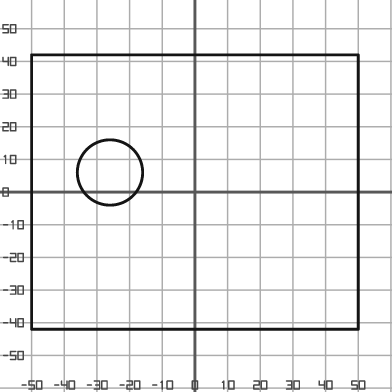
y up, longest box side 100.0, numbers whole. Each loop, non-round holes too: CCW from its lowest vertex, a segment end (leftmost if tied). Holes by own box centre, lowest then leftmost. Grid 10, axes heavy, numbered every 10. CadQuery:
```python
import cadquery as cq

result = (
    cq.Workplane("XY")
    .moveTo(-50.0, -42.0)
    .lineTo(50.0, -42.0)
    .lineTo(50.0, 42.0)
    .lineTo(-50.0, 42.0)
    .close()
    .moveTo(-26.0, 6.0)
    .circle(10.0)
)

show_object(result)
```